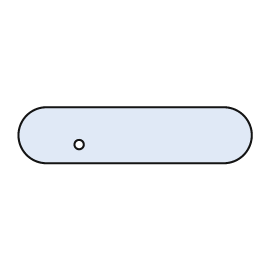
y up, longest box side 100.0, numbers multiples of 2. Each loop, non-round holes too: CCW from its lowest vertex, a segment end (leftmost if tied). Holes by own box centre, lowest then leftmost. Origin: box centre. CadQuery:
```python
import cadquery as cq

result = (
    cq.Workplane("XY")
    .moveTo(-38.0, -12.0)
    .lineTo(38.0, -12.0)
    .threePointArc((50.0, 0.0), (38.0, 12.0))
    .lineTo(-38.0, 12.0)
    .threePointArc((-50.0, 0.0), (-38.0, -12.0))
    .close()
    .moveTo(-24.0, -4.0)
    .circle(2.0)
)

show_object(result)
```